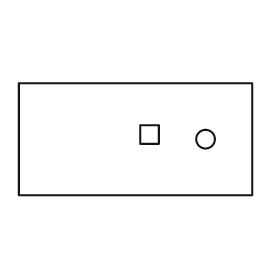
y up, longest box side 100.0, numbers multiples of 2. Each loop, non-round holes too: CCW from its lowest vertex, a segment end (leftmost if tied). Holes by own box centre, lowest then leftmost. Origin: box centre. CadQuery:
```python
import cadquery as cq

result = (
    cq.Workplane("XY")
    .moveTo(-50.0, -24.0)
    .lineTo(50.0, -24.0)
    .lineTo(50.0, 24.0)
    .lineTo(-50.0, 24.0)
    .close()
    .moveTo(30.0, 0.0)
    .circle(4.0)
    .moveTo(2.0, -2.0)
    .lineTo(10.0, -2.0)
    .lineTo(10.0, 6.0)
    .lineTo(2.0, 6.0)
    .close()
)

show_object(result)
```